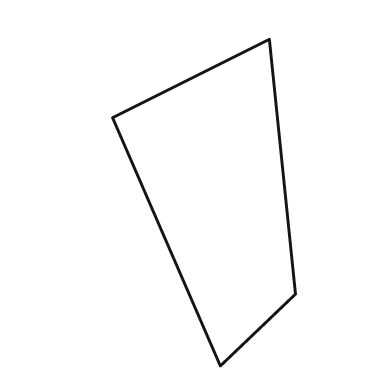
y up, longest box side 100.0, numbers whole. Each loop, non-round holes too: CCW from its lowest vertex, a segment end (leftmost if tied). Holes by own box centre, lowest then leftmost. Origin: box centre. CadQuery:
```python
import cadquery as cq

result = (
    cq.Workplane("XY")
    .moveTo(5.0, -50.0)
    .lineTo(28.0, -28.0)
    .lineTo(20.0, 50.0)
    .lineTo(-28.0, 26.0)
    .close()
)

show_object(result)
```